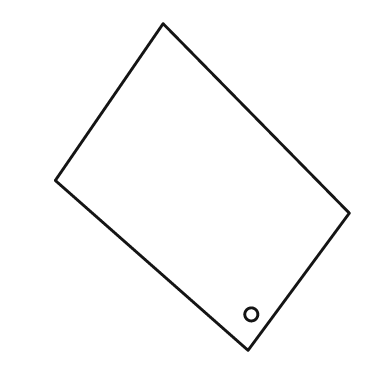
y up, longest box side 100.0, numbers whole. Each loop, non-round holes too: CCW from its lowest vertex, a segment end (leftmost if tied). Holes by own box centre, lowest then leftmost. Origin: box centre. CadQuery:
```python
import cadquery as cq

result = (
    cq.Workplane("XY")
    .moveTo(14.0, -50.0)
    .lineTo(45.0, -8.0)
    .lineTo(-12.0, 50.0)
    .lineTo(-45.0, 2.0)
    .close()
    .moveTo(15.0, -39.0)
    .circle(2.0)
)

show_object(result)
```